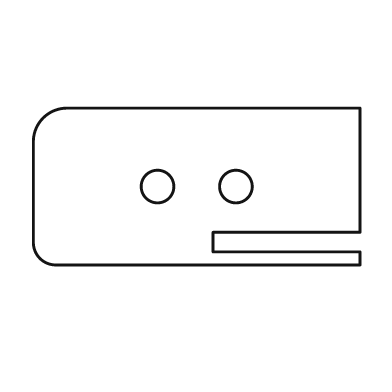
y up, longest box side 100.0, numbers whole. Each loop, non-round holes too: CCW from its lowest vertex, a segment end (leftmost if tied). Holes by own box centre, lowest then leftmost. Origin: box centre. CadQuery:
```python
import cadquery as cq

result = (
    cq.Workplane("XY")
    .moveTo(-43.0, -24.0)
    .lineTo(50.0, -24.0)
    .lineTo(50.0, -20.0)
    .lineTo(5.0, -20.0)
    .lineTo(5.0, -14.0)
    .lineTo(50.0, -14.0)
    .lineTo(50.0, 24.0)
    .lineTo(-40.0, 24.0)
    .threePointArc((-47.0, 21.0), (-50.0, 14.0))
    .lineTo(-50.0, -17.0)
    .threePointArc((-48.0, -22.0), (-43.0, -24.0))
    .close()
    .moveTo(-12.0, 0.0)
    .circle(5.0)
    .moveTo(12.0, 0.0)
    .circle(5.0)
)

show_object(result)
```